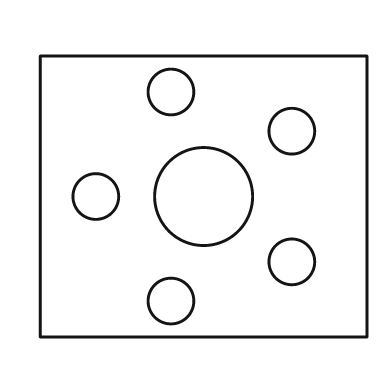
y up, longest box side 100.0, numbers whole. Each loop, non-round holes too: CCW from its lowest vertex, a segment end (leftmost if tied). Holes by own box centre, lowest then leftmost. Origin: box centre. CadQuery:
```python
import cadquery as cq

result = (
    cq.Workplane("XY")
    .moveTo(-50.0, -43.0)
    .lineTo(50.0, -43.0)
    .lineTo(50.0, 43.0)
    .lineTo(-50.0, 43.0)
    .close()
    .moveTo(-10.0, -32.0)
    .circle(7.0)
    .moveTo(27.0, -20.0)
    .circle(7.0)
    .moveTo(-33.0, 0.0)
    .circle(7.0)
    .moveTo(0.0, 0.0)
    .circle(15.0)
    .moveTo(27.0, 20.0)
    .circle(7.0)
    .moveTo(-10.0, 32.0)
    .circle(7.0)
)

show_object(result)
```